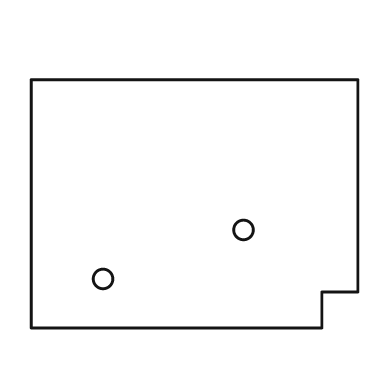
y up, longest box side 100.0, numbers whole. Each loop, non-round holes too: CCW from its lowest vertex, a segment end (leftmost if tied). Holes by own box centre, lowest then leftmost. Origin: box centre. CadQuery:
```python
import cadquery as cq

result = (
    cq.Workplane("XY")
    .moveTo(-50.0, -38.0)
    .lineTo(39.0, -38.0)
    .lineTo(39.0, -27.0)
    .lineTo(50.0, -27.0)
    .lineTo(50.0, 38.0)
    .lineTo(-50.0, 38.0)
    .close()
    .moveTo(-28.0, -23.0)
    .circle(3.0)
    .moveTo(15.0, -8.0)
    .circle(3.0)
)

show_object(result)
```